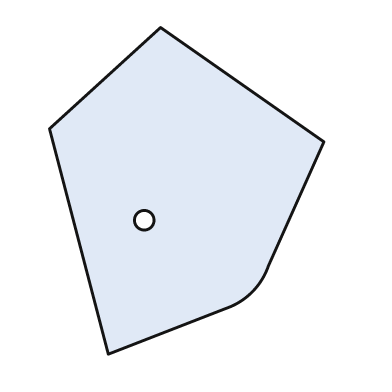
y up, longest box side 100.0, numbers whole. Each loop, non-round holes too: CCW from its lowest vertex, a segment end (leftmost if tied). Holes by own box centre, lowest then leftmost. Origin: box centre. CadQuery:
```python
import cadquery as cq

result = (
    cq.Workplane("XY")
    .moveTo(-24.0, -50.0)
    .lineTo(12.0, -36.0)
    .threePointArc((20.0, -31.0), (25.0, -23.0))
    .lineTo(42.0, 15.0)
    .lineTo(-8.0, 50.0)
    .lineTo(-42.0, 19.0)
    .close()
    .moveTo(-13.0, -9.0)
    .circle(3.0)
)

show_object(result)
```